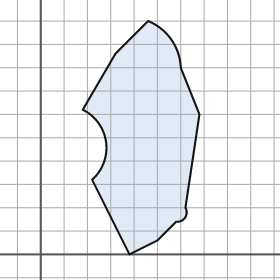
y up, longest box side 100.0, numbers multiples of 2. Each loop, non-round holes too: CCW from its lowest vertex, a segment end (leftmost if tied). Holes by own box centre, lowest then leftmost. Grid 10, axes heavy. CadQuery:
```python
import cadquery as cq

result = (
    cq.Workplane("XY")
    .moveTo(38.0, 0.0)
    .lineTo(50.0, 6.0)
    .lineTo(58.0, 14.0)
    .threePointArc((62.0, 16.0), (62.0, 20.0))
    .lineTo(68.0, 60.0)
    .lineTo(60.0, 80.0)
    .threePointArc((56.0, 92.0), (46.0, 100.0))
    .lineTo(32.0, 86.0)
    .lineTo(18.0, 62.0)
    .threePointArc((28.0, 48.0), (22.0, 32.0))
    .close()
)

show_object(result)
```